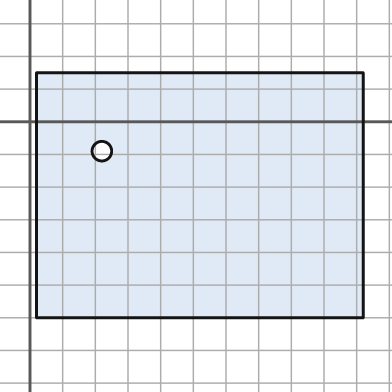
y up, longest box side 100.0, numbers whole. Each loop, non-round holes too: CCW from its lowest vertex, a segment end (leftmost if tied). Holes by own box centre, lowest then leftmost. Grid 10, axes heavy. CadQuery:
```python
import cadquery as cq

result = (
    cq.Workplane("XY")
    .moveTo(2.0, -60.0)
    .lineTo(102.0, -60.0)
    .lineTo(102.0, 15.0)
    .lineTo(2.0, 15.0)
    .close()
    .moveTo(22.0, -9.0)
    .circle(3.0)
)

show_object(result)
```